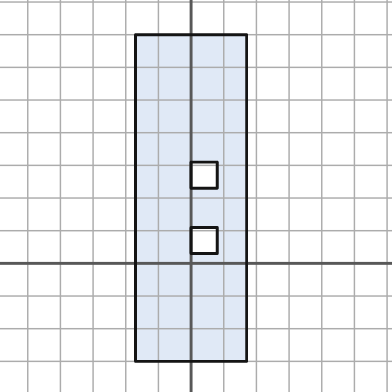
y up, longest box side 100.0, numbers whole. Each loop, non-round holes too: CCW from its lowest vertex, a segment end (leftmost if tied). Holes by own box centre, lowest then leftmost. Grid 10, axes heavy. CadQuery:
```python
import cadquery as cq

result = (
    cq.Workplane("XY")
    .moveTo(-17.0, -30.0)
    .lineTo(17.0, -30.0)
    .lineTo(17.0, 70.0)
    .lineTo(-17.0, 70.0)
    .close()
    .moveTo(0.0, 3.0)
    .lineTo(8.0, 3.0)
    .lineTo(8.0, 11.0)
    .lineTo(0.0, 11.0)
    .close()
    .moveTo(0.0, 23.0)
    .lineTo(8.0, 23.0)
    .lineTo(8.0, 31.0)
    .lineTo(0.0, 31.0)
    .close()
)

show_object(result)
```